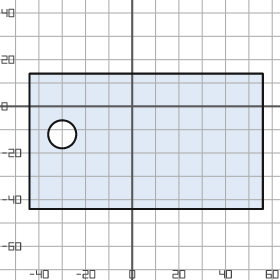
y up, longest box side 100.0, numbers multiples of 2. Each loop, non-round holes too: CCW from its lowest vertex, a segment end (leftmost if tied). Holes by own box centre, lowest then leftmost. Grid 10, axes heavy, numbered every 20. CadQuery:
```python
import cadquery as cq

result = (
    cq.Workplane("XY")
    .moveTo(-44.0, -44.0)
    .lineTo(56.0, -44.0)
    .lineTo(56.0, 14.0)
    .lineTo(-44.0, 14.0)
    .close()
    .moveTo(-30.0, -12.0)
    .circle(6.0)
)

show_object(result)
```